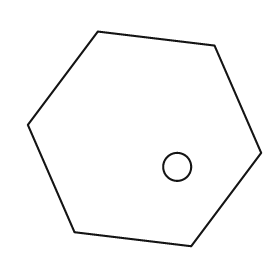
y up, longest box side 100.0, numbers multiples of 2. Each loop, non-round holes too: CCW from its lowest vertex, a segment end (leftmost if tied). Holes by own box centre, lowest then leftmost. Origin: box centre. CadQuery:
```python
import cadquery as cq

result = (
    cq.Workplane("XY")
    .moveTo(20.0, -46.0)
    .lineTo(50.0, -6.0)
    .lineTo(30.0, 40.0)
    .lineTo(-20.0, 46.0)
    .lineTo(-50.0, 6.0)
    .lineTo(-30.0, -40.0)
    .close()
    .moveTo(14.0, -12.0)
    .circle(6.0)
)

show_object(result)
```